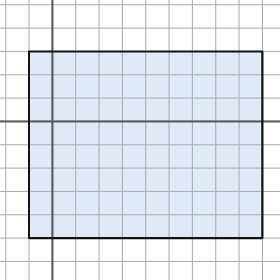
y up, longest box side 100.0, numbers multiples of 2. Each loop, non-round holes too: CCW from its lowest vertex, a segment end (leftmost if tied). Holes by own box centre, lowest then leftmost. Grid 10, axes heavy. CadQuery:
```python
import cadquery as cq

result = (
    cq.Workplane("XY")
    .moveTo(-10.0, -50.0)
    .lineTo(90.0, -50.0)
    .lineTo(90.0, 30.0)
    .lineTo(-10.0, 30.0)
    .close()
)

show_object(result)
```